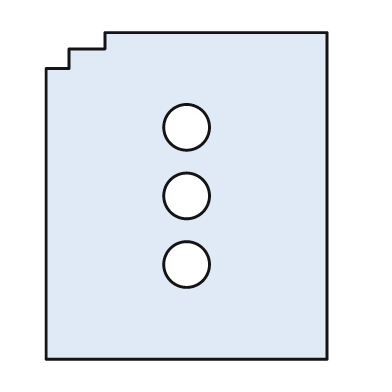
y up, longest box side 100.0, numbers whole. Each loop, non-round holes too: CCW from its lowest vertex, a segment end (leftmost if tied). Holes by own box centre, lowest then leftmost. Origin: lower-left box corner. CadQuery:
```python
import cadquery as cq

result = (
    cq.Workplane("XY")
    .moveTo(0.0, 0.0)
    .lineTo(86.0, 0.0)
    .lineTo(86.0, 100.0)
    .lineTo(18.0, 100.0)
    .lineTo(18.0, 95.0)
    .lineTo(7.0, 95.0)
    .lineTo(7.0, 89.0)
    .lineTo(0.0, 89.0)
    .close()
    .moveTo(43.0, 29.0)
    .circle(7.0)
    .moveTo(43.0, 50.0)
    .circle(7.0)
    .moveTo(43.0, 71.0)
    .circle(7.0)
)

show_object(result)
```